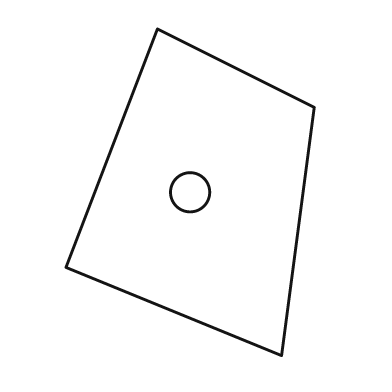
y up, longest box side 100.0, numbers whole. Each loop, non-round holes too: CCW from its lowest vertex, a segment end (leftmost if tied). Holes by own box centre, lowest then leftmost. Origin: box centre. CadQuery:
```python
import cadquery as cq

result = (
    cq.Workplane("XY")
    .moveTo(28.0, -50.0)
    .lineTo(38.0, 26.0)
    .lineTo(-10.0, 50.0)
    .lineTo(-38.0, -23.0)
    .close()
    .moveTo(0.0, 0.0)
    .circle(6.0)
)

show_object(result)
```